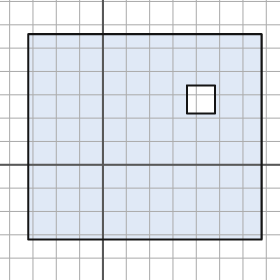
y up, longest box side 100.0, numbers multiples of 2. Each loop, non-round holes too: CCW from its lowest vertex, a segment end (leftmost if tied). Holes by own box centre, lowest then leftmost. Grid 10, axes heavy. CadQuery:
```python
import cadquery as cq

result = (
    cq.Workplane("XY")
    .moveTo(-32.0, -32.0)
    .lineTo(68.0, -32.0)
    .lineTo(68.0, 56.0)
    .lineTo(-32.0, 56.0)
    .close()
    .moveTo(36.0, 22.0)
    .lineTo(48.0, 22.0)
    .lineTo(48.0, 34.0)
    .lineTo(36.0, 34.0)
    .close()
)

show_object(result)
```